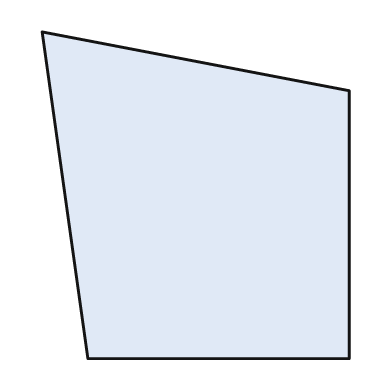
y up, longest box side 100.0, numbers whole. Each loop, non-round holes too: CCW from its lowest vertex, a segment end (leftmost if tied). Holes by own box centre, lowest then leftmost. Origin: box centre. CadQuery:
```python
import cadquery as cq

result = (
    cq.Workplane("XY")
    .moveTo(-33.0, -50.0)
    .lineTo(47.0, -50.0)
    .lineTo(47.0, 32.0)
    .lineTo(-47.0, 50.0)
    .close()
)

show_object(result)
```